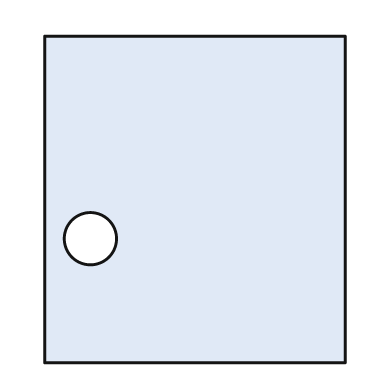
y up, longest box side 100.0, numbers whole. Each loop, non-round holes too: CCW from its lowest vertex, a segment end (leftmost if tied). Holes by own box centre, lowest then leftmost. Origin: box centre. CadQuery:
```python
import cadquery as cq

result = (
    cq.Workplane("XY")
    .moveTo(-46.0, -50.0)
    .lineTo(46.0, -50.0)
    .lineTo(46.0, 50.0)
    .lineTo(-46.0, 50.0)
    .close()
    .moveTo(-32.0, -12.0)
    .circle(8.0)
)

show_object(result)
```